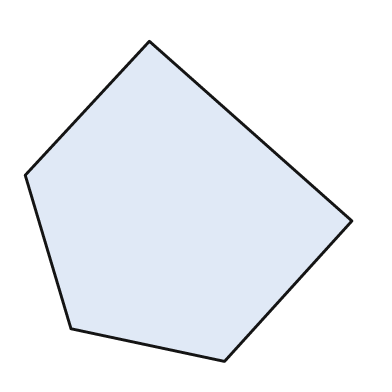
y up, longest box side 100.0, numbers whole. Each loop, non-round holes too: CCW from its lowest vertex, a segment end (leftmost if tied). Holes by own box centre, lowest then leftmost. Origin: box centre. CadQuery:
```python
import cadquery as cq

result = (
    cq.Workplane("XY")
    .moveTo(11.0, -49.0)
    .lineTo(50.0, -6.0)
    .lineTo(-12.0, 49.0)
    .lineTo(-50.0, 8.0)
    .lineTo(-36.0, -39.0)
    .close()
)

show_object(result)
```